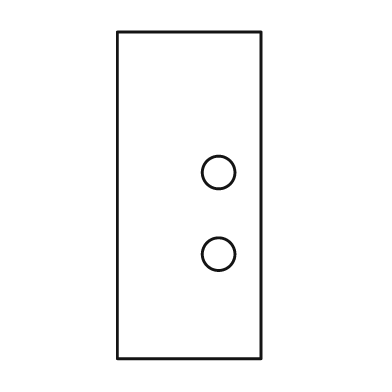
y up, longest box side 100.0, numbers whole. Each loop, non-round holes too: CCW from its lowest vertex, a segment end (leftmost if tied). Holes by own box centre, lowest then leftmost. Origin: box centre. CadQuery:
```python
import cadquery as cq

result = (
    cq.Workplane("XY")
    .moveTo(-22.0, -50.0)
    .lineTo(22.0, -50.0)
    .lineTo(22.0, 50.0)
    .lineTo(-22.0, 50.0)
    .close()
    .moveTo(9.0, -18.0)
    .circle(5.0)
    .moveTo(9.0, 7.0)
    .circle(5.0)
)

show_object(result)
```